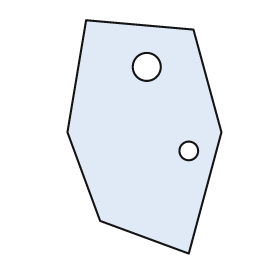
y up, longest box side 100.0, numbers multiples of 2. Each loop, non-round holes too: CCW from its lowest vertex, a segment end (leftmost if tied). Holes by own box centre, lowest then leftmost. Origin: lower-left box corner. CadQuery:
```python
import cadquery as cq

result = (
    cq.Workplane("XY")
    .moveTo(52.0, 0.0)
    .lineTo(66.0, 52.0)
    .lineTo(54.0, 96.0)
    .lineTo(8.0, 100.0)
    .lineTo(0.0, 52.0)
    .lineTo(14.0, 14.0)
    .close()
    .moveTo(52.0, 44.0)
    .circle(4.0)
    .moveTo(34.0, 80.0)
    .circle(6.0)
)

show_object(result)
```